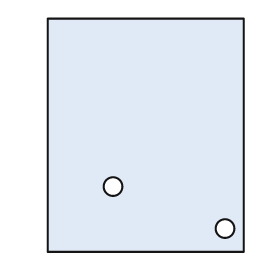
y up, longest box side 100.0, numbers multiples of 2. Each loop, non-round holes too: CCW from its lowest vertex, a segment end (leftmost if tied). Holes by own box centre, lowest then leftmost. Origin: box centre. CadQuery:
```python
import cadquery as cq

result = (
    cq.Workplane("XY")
    .moveTo(-42.0, -50.0)
    .lineTo(42.0, -50.0)
    .lineTo(42.0, 50.0)
    .lineTo(-42.0, 50.0)
    .close()
    .moveTo(34.0, -40.0)
    .circle(4.0)
    .moveTo(-14.0, -22.0)
    .circle(4.0)
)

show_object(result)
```